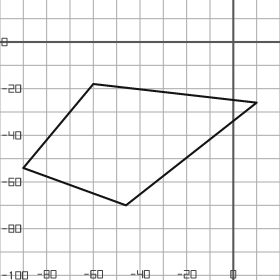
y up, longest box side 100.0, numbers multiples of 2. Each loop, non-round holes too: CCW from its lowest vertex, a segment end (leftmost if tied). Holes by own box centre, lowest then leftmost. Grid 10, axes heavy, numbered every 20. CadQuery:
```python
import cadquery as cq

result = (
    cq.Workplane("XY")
    .moveTo(-46.0, -70.0)
    .lineTo(10.0, -26.0)
    .lineTo(-60.0, -18.0)
    .lineTo(-90.0, -54.0)
    .close()
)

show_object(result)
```